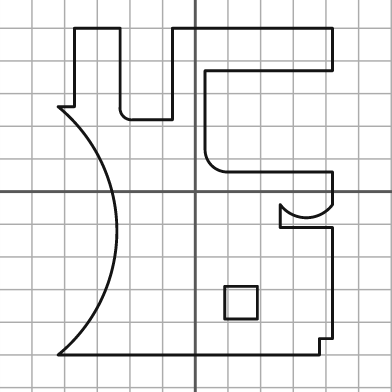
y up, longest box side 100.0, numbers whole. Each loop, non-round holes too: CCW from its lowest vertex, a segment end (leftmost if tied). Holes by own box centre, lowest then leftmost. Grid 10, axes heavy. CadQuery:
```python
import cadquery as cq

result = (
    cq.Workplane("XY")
    .moveTo(-42.0, -50.0)
    .lineTo(38.0, -50.0)
    .lineTo(38.0, -45.0)
    .lineTo(42.0, -45.0)
    .lineTo(42.0, -11.0)
    .lineTo(26.0, -11.0)
    .lineTo(26.0, -4.0)
    .threePointArc((34.0, -8.0), (42.0, -4.0))
    .lineTo(42.0, 6.0)
    .lineTo(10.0, 6.0)
    .threePointArc((5.0, 8.0), (3.0, 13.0))
    .lineTo(3.0, 37.0)
    .lineTo(42.0, 37.0)
    .lineTo(42.0, 50.0)
    .lineTo(-7.0, 50.0)
    .lineTo(-7.0, 22.0)
    .lineTo(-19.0, 22.0)
    .threePointArc((-22.0, 23.0), (-23.0, 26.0))
    .lineTo(-23.0, 50.0)
    .lineTo(-37.0, 50.0)
    .lineTo(-37.0, 26.0)
    .lineTo(-42.0, 26.0)
    .threePointArc((-24.0, -12.0), (-42.0, -50.0))
    .close()
    .moveTo(9.0, -39.0)
    .lineTo(19.0, -39.0)
    .lineTo(19.0, -29.0)
    .lineTo(9.0, -29.0)
    .close()
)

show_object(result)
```